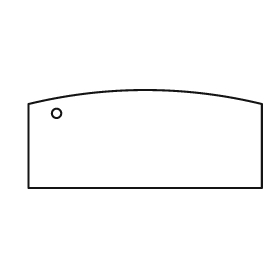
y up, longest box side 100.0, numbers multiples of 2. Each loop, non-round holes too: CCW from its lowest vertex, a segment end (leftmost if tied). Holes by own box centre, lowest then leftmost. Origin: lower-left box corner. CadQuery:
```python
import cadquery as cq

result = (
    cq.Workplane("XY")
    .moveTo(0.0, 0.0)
    .lineTo(100.0, 0.0)
    .lineTo(100.0, 36.0)
    .threePointArc((50.0, 42.0), (0.0, 36.0))
    .close()
    .moveTo(12.0, 32.0)
    .circle(2.0)
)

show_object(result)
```